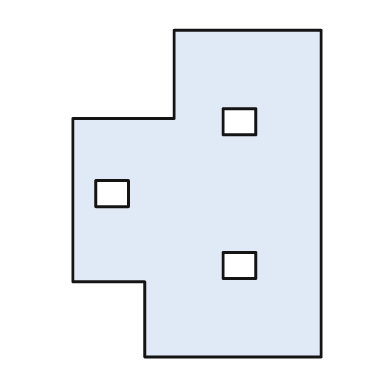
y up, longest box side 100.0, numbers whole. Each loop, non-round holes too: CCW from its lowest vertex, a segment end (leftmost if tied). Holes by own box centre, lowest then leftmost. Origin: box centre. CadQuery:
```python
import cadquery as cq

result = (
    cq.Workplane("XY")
    .moveTo(-16.0, -50.0)
    .lineTo(38.0, -50.0)
    .lineTo(38.0, 50.0)
    .lineTo(-7.0, 50.0)
    .lineTo(-7.0, 23.0)
    .lineTo(-38.0, 23.0)
    .lineTo(-38.0, -27.0)
    .lineTo(-16.0, -27.0)
    .close()
    .moveTo(8.0, -26.0)
    .lineTo(18.0, -26.0)
    .lineTo(18.0, -18.0)
    .lineTo(8.0, -18.0)
    .close()
    .moveTo(-31.0, -4.0)
    .lineTo(-21.0, -4.0)
    .lineTo(-21.0, 4.0)
    .lineTo(-31.0, 4.0)
    .close()
    .moveTo(8.0, 18.0)
    .lineTo(18.0, 18.0)
    .lineTo(18.0, 26.0)
    .lineTo(8.0, 26.0)
    .close()
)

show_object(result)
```